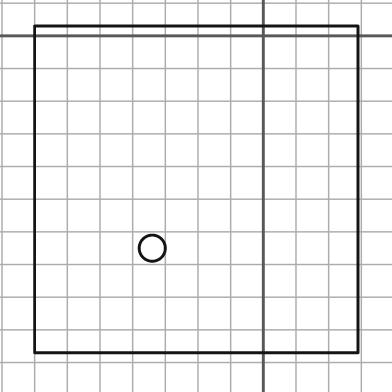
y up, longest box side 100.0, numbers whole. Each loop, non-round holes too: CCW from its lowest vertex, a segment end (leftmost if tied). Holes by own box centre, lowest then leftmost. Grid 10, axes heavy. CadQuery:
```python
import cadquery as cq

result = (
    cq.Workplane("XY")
    .moveTo(-70.0, -97.0)
    .lineTo(29.0, -97.0)
    .lineTo(29.0, 3.0)
    .lineTo(-70.0, 3.0)
    .close()
    .moveTo(-34.0, -65.0)
    .circle(4.0)
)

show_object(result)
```